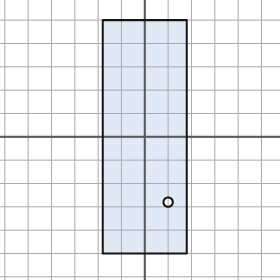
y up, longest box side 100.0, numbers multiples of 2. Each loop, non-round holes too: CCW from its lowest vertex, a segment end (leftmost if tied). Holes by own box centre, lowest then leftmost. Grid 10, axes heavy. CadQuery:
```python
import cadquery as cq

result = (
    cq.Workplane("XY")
    .moveTo(-18.0, -50.0)
    .lineTo(18.0, -50.0)
    .lineTo(18.0, 50.0)
    .lineTo(-18.0, 50.0)
    .close()
    .moveTo(10.0, -28.0)
    .circle(2.0)
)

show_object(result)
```